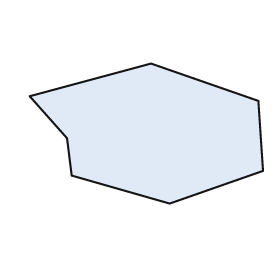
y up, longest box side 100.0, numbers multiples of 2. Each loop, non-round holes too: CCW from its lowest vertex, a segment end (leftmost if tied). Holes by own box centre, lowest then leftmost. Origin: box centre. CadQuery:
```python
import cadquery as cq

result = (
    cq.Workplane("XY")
    .moveTo(10.0, -30.0)
    .lineTo(50.0, -16.0)
    .lineTo(48.0, 14.0)
    .lineTo(2.0, 30.0)
    .lineTo(-50.0, 16.0)
    .lineTo(-34.0, -2.0)
    .lineTo(-32.0, -18.0)
    .close()
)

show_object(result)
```